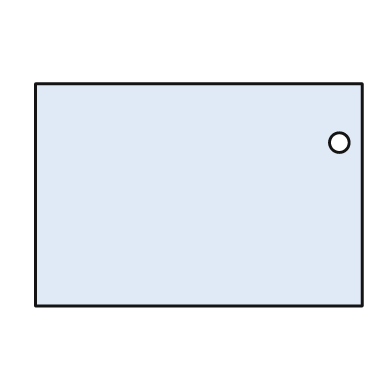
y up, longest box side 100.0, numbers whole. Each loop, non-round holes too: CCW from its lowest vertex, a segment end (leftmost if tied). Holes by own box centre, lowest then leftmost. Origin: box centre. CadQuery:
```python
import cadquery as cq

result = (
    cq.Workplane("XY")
    .moveTo(-50.0, -34.0)
    .lineTo(50.0, -34.0)
    .lineTo(50.0, 34.0)
    .lineTo(-50.0, 34.0)
    .close()
    .moveTo(43.0, 16.0)
    .circle(3.0)
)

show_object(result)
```